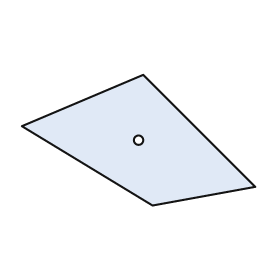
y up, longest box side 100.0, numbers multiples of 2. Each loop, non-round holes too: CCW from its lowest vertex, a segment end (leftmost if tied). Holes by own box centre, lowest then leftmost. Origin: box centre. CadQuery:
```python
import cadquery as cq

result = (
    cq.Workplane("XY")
    .moveTo(6.0, -28.0)
    .lineTo(50.0, -20.0)
    .lineTo(2.0, 28.0)
    .lineTo(-50.0, 6.0)
    .close()
    .moveTo(0.0, 0.0)
    .circle(2.0)
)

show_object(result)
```